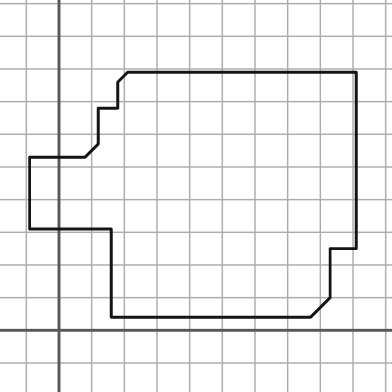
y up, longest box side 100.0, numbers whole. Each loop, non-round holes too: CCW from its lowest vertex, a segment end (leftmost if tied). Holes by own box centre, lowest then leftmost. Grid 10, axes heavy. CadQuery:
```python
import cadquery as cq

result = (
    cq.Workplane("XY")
    .moveTo(16.0, 4.0)
    .lineTo(77.0, 4.0)
    .lineTo(83.0, 10.0)
    .lineTo(83.0, 25.0)
    .lineTo(91.0, 25.0)
    .lineTo(91.0, 79.0)
    .lineTo(21.0, 79.0)
    .lineTo(18.0, 76.0)
    .lineTo(18.0, 68.0)
    .lineTo(12.0, 68.0)
    .lineTo(12.0, 57.0)
    .lineTo(8.0, 53.0)
    .lineTo(-9.0, 53.0)
    .lineTo(-9.0, 31.0)
    .lineTo(16.0, 31.0)
    .close()
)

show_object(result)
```